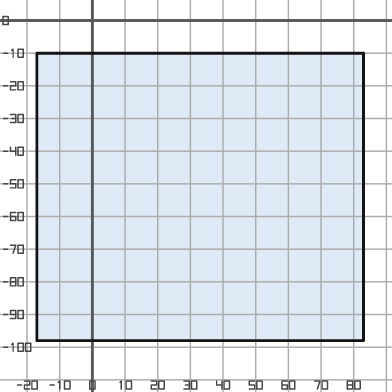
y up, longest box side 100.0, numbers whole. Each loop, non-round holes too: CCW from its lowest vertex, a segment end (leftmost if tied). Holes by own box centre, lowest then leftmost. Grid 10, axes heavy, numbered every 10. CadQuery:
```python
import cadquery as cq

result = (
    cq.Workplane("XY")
    .moveTo(-17.0, -98.0)
    .lineTo(83.0, -98.0)
    .lineTo(83.0, -10.0)
    .lineTo(-17.0, -10.0)
    .close()
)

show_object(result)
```